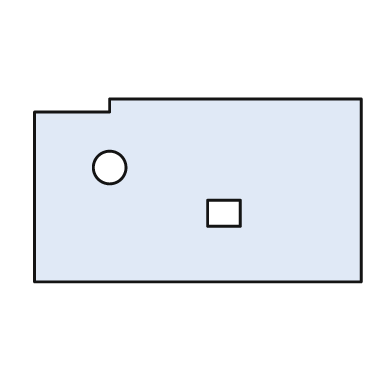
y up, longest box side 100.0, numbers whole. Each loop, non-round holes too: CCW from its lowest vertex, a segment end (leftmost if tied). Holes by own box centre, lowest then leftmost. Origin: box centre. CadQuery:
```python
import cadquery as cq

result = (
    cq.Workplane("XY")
    .moveTo(-50.0, -28.0)
    .lineTo(50.0, -28.0)
    .lineTo(50.0, 28.0)
    .lineTo(-27.0, 28.0)
    .lineTo(-27.0, 24.0)
    .lineTo(-50.0, 24.0)
    .close()
    .moveTo(3.0, -11.0)
    .lineTo(13.0, -11.0)
    .lineTo(13.0, -3.0)
    .lineTo(3.0, -3.0)
    .close()
    .moveTo(-27.0, 7.0)
    .circle(5.0)
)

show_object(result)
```